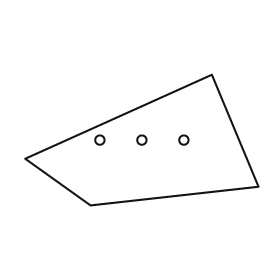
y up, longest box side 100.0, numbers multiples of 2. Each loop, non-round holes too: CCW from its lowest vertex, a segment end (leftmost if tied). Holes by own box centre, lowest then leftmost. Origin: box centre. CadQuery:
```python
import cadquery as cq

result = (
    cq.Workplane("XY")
    .moveTo(-22.0, -28.0)
    .lineTo(50.0, -20.0)
    .lineTo(30.0, 28.0)
    .lineTo(-50.0, -8.0)
    .close()
    .moveTo(-18.0, 0.0)
    .circle(2.0)
    .moveTo(0.0, 0.0)
    .circle(2.0)
    .moveTo(18.0, 0.0)
    .circle(2.0)
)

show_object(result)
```